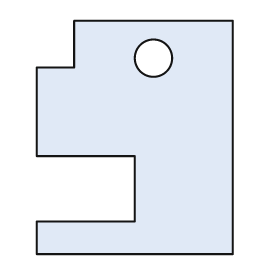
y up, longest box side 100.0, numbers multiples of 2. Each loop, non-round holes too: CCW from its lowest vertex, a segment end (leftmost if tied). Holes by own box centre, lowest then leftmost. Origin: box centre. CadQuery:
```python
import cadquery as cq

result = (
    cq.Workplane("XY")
    .moveTo(-42.0, -50.0)
    .lineTo(42.0, -50.0)
    .lineTo(42.0, 50.0)
    .lineTo(-26.0, 50.0)
    .lineTo(-26.0, 30.0)
    .lineTo(-42.0, 30.0)
    .lineTo(-42.0, -8.0)
    .lineTo(0.0, -8.0)
    .lineTo(0.0, -36.0)
    .lineTo(-42.0, -36.0)
    .close()
    .moveTo(8.0, 34.0)
    .circle(8.0)
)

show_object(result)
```